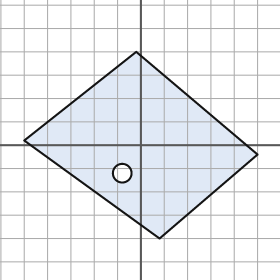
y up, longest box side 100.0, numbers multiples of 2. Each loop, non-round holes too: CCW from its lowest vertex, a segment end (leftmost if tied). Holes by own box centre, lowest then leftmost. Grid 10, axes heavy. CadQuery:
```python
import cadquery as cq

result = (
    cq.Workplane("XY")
    .moveTo(8.0, -40.0)
    .lineTo(50.0, -4.0)
    .lineTo(-2.0, 40.0)
    .lineTo(-50.0, 2.0)
    .close()
    .moveTo(-8.0, -12.0)
    .circle(4.0)
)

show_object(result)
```